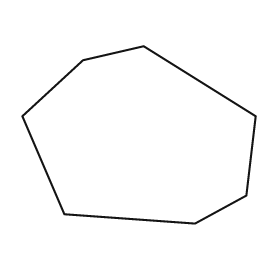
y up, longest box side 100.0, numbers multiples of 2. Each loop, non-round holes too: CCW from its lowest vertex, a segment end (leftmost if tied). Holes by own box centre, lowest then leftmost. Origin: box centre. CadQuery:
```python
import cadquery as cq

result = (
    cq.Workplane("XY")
    .moveTo(24.0, -38.0)
    .lineTo(46.0, -26.0)
    .lineTo(50.0, 8.0)
    .lineTo(2.0, 38.0)
    .lineTo(-24.0, 32.0)
    .lineTo(-50.0, 8.0)
    .lineTo(-32.0, -34.0)
    .close()
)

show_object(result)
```